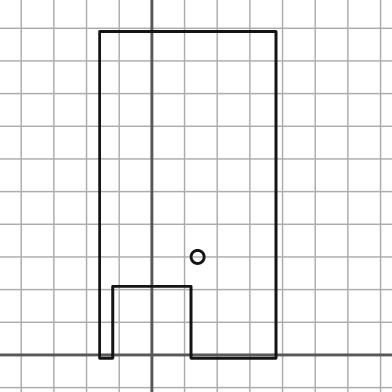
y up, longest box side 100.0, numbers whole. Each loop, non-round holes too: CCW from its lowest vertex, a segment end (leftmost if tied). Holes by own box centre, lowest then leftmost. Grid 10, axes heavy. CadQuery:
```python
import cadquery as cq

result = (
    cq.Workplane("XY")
    .moveTo(-16.0, -1.0)
    .lineTo(-12.0, -1.0)
    .lineTo(-12.0, 21.0)
    .lineTo(12.0, 21.0)
    .lineTo(12.0, -1.0)
    .lineTo(38.0, -1.0)
    .lineTo(38.0, 99.0)
    .lineTo(-16.0, 99.0)
    .close()
    .moveTo(14.0, 30.0)
    .circle(2.0)
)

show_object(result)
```